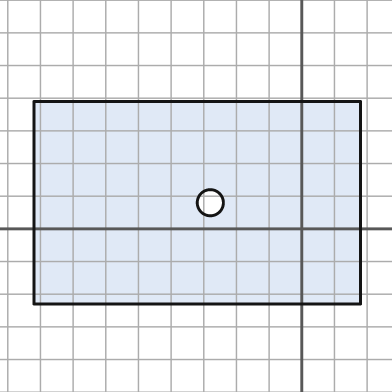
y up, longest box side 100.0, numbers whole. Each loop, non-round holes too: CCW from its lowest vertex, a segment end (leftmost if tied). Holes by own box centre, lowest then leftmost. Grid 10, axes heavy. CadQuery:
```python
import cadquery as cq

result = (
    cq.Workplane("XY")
    .moveTo(-82.0, -23.0)
    .lineTo(18.0, -23.0)
    .lineTo(18.0, 39.0)
    .lineTo(-82.0, 39.0)
    .close()
    .moveTo(-28.0, 8.0)
    .circle(4.0)
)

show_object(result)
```